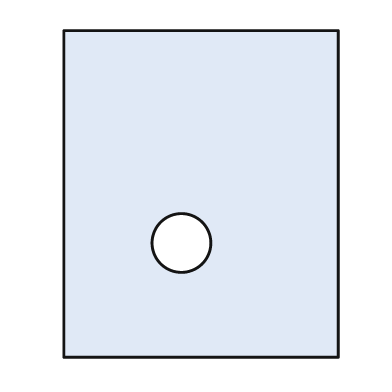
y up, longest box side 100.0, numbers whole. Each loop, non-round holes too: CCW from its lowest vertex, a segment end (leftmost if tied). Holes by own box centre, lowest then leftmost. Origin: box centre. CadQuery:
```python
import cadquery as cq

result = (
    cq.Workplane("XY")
    .moveTo(-42.0, -50.0)
    .lineTo(42.0, -50.0)
    .lineTo(42.0, 50.0)
    .lineTo(-42.0, 50.0)
    .close()
    .moveTo(-6.0, -15.0)
    .circle(9.0)
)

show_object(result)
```